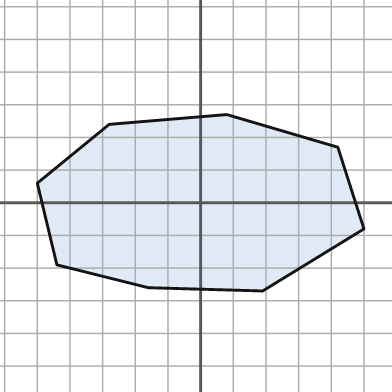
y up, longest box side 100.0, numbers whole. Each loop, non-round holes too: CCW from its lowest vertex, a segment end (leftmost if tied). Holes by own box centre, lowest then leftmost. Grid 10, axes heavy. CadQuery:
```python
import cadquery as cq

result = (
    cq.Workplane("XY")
    .moveTo(19.0, -27.0)
    .lineTo(50.0, -8.0)
    .lineTo(42.0, 17.0)
    .lineTo(8.0, 27.0)
    .lineTo(-28.0, 24.0)
    .lineTo(-50.0, 6.0)
    .lineTo(-44.0, -19.0)
    .lineTo(-16.0, -26.0)
    .close()
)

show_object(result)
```